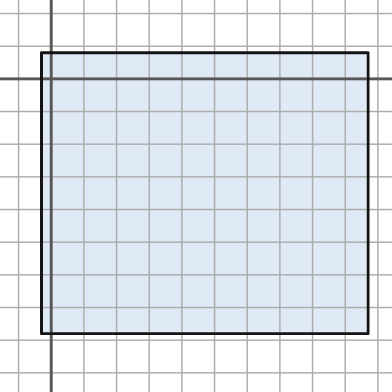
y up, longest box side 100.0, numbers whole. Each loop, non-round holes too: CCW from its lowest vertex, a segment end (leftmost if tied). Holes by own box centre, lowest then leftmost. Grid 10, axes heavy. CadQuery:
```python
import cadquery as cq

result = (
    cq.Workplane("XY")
    .moveTo(-3.0, -78.0)
    .lineTo(97.0, -78.0)
    .lineTo(97.0, 8.0)
    .lineTo(-3.0, 8.0)
    .close()
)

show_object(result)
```